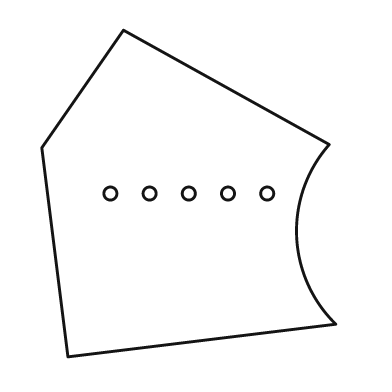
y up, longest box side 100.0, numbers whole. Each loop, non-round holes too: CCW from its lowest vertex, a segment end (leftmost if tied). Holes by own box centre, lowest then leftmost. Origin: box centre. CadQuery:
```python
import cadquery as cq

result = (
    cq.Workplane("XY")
    .moveTo(-37.0, -50.0)
    .lineTo(45.0, -40.0)
    .threePointArc((33.0, -13.0), (43.0, 15.0))
    .lineTo(-20.0, 50.0)
    .lineTo(-45.0, 14.0)
    .close()
    .moveTo(-24.0, 0.0)
    .circle(2.0)
    .moveTo(-12.0, 0.0)
    .circle(2.0)
    .moveTo(0.0, 0.0)
    .circle(2.0)
    .moveTo(12.0, 0.0)
    .circle(2.0)
    .moveTo(24.0, 0.0)
    .circle(2.0)
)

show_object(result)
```